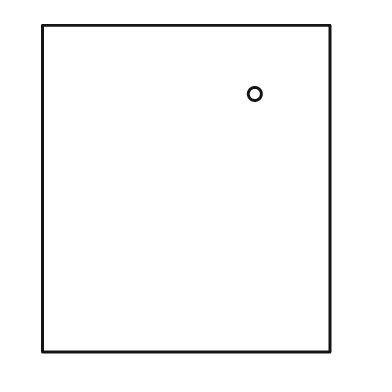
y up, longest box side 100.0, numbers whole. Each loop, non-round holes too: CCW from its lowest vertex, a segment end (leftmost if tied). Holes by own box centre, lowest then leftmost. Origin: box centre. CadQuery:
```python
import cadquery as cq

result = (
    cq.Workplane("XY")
    .moveTo(-44.0, -50.0)
    .lineTo(44.0, -50.0)
    .lineTo(44.0, 50.0)
    .lineTo(-44.0, 50.0)
    .close()
    .moveTo(21.0, 29.0)
    .circle(2.0)
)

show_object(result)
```